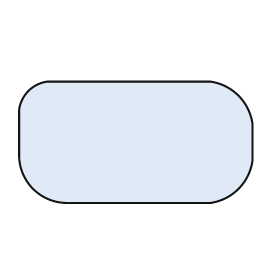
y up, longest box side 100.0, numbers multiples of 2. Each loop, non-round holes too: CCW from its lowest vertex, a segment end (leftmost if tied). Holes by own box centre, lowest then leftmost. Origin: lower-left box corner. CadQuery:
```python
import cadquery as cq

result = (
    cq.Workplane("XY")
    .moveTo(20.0, 0.0)
    .lineTo(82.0, 0.0)
    .threePointArc((94.0, 6.0), (100.0, 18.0))
    .lineTo(100.0, 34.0)
    .threePointArc((94.0, 46.0), (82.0, 52.0))
    .lineTo(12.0, 52.0)
    .threePointArc((4.0, 48.0), (0.0, 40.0))
    .lineTo(0.0, 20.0)
    .threePointArc((6.0, 6.0), (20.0, 0.0))
    .close()
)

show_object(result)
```